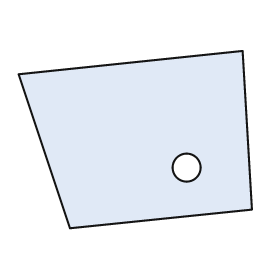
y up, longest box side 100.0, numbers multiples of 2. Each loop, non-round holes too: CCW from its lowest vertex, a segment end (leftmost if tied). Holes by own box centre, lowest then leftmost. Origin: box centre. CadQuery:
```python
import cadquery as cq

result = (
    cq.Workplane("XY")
    .moveTo(-28.0, -38.0)
    .lineTo(50.0, -30.0)
    .lineTo(46.0, 38.0)
    .lineTo(-50.0, 28.0)
    .close()
    .moveTo(22.0, -12.0)
    .circle(6.0)
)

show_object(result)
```